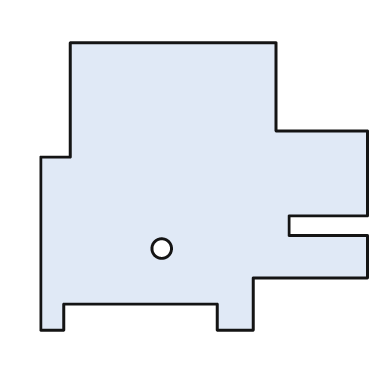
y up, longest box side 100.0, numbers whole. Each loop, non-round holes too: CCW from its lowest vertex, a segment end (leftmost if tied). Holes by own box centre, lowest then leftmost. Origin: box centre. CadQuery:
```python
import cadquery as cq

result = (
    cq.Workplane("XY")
    .moveTo(-50.0, -44.0)
    .lineTo(-43.0, -44.0)
    .lineTo(-43.0, -36.0)
    .lineTo(4.0, -36.0)
    .lineTo(4.0, -44.0)
    .lineTo(15.0, -44.0)
    .lineTo(15.0, -28.0)
    .lineTo(50.0, -28.0)
    .lineTo(50.0, -15.0)
    .lineTo(26.0, -15.0)
    .lineTo(26.0, -9.0)
    .lineTo(50.0, -9.0)
    .lineTo(50.0, 17.0)
    .lineTo(22.0, 17.0)
    .lineTo(22.0, 44.0)
    .lineTo(-41.0, 44.0)
    .lineTo(-41.0, 9.0)
    .lineTo(-50.0, 9.0)
    .close()
    .moveTo(-13.0, -19.0)
    .circle(3.0)
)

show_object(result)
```